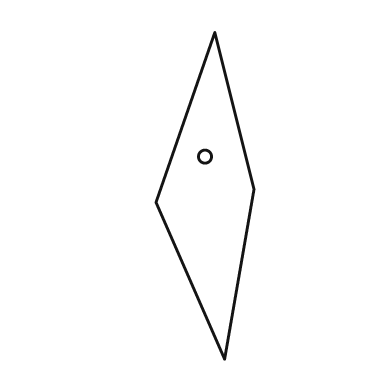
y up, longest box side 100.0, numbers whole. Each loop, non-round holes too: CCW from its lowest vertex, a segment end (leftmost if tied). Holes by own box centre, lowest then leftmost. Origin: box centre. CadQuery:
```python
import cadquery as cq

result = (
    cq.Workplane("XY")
    .moveTo(6.0, -50.0)
    .lineTo(15.0, 2.0)
    .lineTo(3.0, 50.0)
    .lineTo(-15.0, -2.0)
    .close()
    .moveTo(0.0, 12.0)
    .circle(2.0)
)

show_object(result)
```